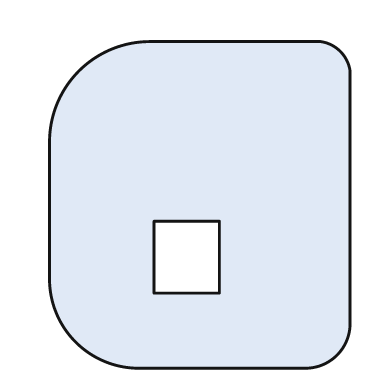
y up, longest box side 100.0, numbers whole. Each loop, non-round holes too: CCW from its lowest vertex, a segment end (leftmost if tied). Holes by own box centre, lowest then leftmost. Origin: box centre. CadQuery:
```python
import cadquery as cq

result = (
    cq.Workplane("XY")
    .moveTo(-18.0, -50.0)
    .lineTo(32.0, -50.0)
    .threePointArc((42.0, -46.0), (46.0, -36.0))
    .lineTo(46.0, 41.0)
    .threePointArc((43.0, 47.0), (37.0, 50.0))
    .lineTo(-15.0, 50.0)
    .threePointArc((-37.0, 41.0), (-46.0, 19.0))
    .lineTo(-46.0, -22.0)
    .threePointArc((-38.0, -42.0), (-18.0, -50.0))
    .close()
    .moveTo(-14.0, -27.0)
    .lineTo(6.0, -27.0)
    .lineTo(6.0, -5.0)
    .lineTo(-14.0, -5.0)
    .close()
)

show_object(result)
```